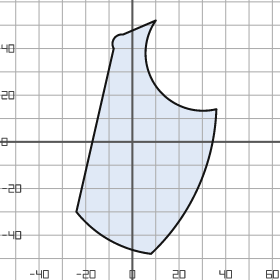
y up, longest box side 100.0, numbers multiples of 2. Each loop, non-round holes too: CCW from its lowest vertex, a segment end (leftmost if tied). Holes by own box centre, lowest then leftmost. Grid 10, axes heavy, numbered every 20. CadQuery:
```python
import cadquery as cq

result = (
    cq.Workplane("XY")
    .moveTo(8.0, -48.0)
    .threePointArc((28.0, -20.0), (36.0, 14.0))
    .threePointArc((10.0, 24.0), (10.0, 52.0))
    .lineTo(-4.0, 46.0)
    .threePointArc((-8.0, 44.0), (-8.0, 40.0))
    .lineTo(-24.0, -30.0)
    .threePointArc((-10.0, -42.0), (8.0, -48.0))
    .close()
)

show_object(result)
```